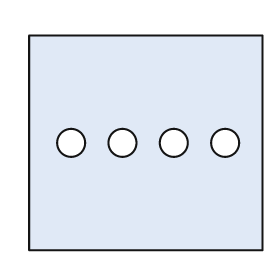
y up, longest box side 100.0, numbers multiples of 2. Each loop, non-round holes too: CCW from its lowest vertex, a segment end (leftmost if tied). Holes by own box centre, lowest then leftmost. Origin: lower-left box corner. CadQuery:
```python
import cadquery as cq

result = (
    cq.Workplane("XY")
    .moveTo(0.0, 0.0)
    .lineTo(100.0, 0.0)
    .lineTo(100.0, 92.0)
    .lineTo(0.0, 92.0)
    .close()
    .moveTo(18.0, 46.0)
    .circle(6.0)
    .moveTo(40.0, 46.0)
    .circle(6.0)
    .moveTo(62.0, 46.0)
    .circle(6.0)
    .moveTo(84.0, 46.0)
    .circle(6.0)
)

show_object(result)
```